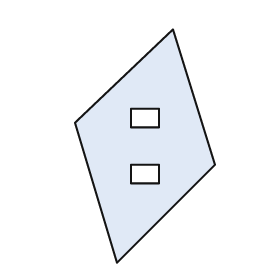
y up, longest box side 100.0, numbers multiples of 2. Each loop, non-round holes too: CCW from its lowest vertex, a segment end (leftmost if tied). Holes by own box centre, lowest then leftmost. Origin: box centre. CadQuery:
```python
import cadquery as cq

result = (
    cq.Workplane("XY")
    .moveTo(-12.0, -50.0)
    .lineTo(30.0, -8.0)
    .lineTo(12.0, 50.0)
    .lineTo(-30.0, 10.0)
    .close()
    .moveTo(-6.0, -16.0)
    .lineTo(6.0, -16.0)
    .lineTo(6.0, -8.0)
    .lineTo(-6.0, -8.0)
    .close()
    .moveTo(-6.0, 8.0)
    .lineTo(6.0, 8.0)
    .lineTo(6.0, 16.0)
    .lineTo(-6.0, 16.0)
    .close()
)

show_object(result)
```